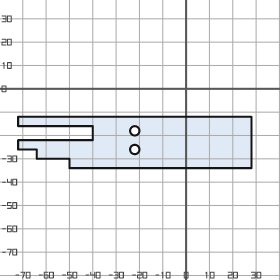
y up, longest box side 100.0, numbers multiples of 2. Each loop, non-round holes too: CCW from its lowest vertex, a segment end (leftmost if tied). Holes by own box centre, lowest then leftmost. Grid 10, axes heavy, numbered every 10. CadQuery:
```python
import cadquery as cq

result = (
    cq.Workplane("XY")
    .moveTo(-50.0, -34.0)
    .lineTo(28.0, -34.0)
    .lineTo(28.0, -12.0)
    .lineTo(-72.0, -12.0)
    .lineTo(-72.0, -16.0)
    .lineTo(-40.0, -16.0)
    .lineTo(-40.0, -22.0)
    .lineTo(-72.0, -22.0)
    .lineTo(-72.0, -26.0)
    .lineTo(-64.0, -26.0)
    .lineTo(-64.0, -30.0)
    .lineTo(-50.0, -30.0)
    .close()
    .moveTo(-22.0, -26.0)
    .circle(2.0)
    .moveTo(-22.0, -18.0)
    .circle(2.0)
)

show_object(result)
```